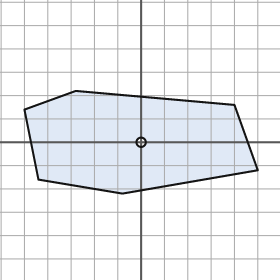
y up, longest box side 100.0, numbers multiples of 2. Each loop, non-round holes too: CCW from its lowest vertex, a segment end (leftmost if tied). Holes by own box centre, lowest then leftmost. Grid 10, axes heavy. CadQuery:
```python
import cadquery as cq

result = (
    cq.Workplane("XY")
    .moveTo(-8.0, -22.0)
    .lineTo(50.0, -12.0)
    .lineTo(40.0, 16.0)
    .lineTo(-28.0, 22.0)
    .lineTo(-50.0, 14.0)
    .lineTo(-44.0, -16.0)
    .close()
    .moveTo(0.0, 0.0)
    .circle(2.0)
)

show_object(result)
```